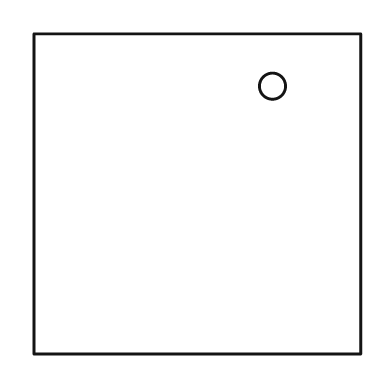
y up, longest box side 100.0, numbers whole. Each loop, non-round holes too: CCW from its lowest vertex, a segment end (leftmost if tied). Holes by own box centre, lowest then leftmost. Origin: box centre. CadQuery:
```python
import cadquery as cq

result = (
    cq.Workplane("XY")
    .moveTo(-50.0, -49.0)
    .lineTo(50.0, -49.0)
    .lineTo(50.0, 49.0)
    .lineTo(-50.0, 49.0)
    .close()
    .moveTo(23.0, 33.0)
    .circle(4.0)
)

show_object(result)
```